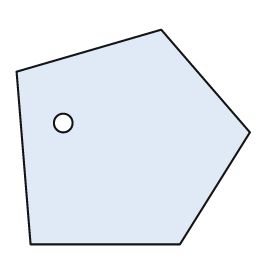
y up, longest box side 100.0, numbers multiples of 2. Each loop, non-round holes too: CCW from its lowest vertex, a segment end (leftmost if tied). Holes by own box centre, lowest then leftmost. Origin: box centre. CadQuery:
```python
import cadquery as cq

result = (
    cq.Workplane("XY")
    .moveTo(-44.0, -46.0)
    .lineTo(20.0, -46.0)
    .lineTo(50.0, 2.0)
    .lineTo(12.0, 46.0)
    .lineTo(-50.0, 28.0)
    .close()
    .moveTo(-30.0, 6.0)
    .circle(4.0)
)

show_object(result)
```